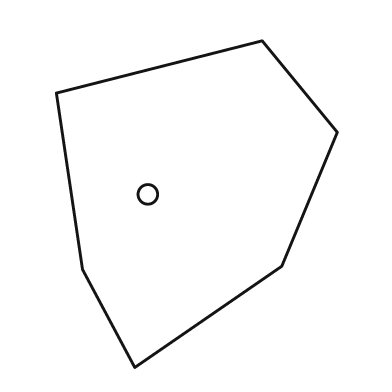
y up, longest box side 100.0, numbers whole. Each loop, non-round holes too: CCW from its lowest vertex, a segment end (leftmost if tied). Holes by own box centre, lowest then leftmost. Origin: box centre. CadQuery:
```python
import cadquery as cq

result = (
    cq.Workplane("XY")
    .moveTo(-19.0, -50.0)
    .lineTo(26.0, -19.0)
    .lineTo(43.0, 22.0)
    .lineTo(20.0, 50.0)
    .lineTo(-43.0, 34.0)
    .lineTo(-35.0, -20.0)
    .close()
    .moveTo(-15.0, 3.0)
    .circle(3.0)
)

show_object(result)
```